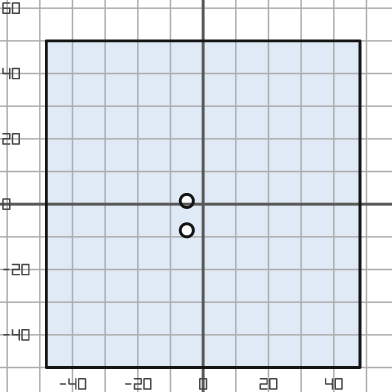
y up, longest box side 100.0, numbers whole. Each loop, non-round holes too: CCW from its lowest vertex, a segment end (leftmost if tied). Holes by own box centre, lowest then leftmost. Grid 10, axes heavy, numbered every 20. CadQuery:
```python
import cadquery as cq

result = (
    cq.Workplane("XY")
    .moveTo(-48.0, -50.0)
    .lineTo(48.0, -50.0)
    .lineTo(48.0, 50.0)
    .lineTo(-48.0, 50.0)
    .close()
    .moveTo(-5.0, -8.0)
    .circle(2.0)
    .moveTo(-5.0, 1.0)
    .circle(2.0)
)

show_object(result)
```